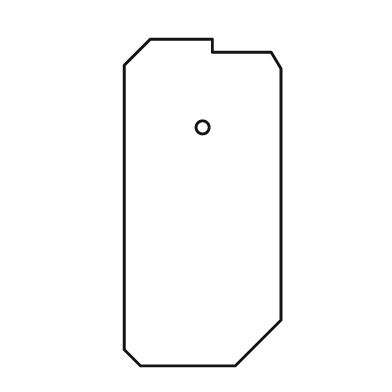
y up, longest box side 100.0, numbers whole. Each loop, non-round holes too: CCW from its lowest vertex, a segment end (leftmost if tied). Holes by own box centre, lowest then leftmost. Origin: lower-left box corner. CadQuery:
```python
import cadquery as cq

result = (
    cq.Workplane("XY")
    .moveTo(5.0, 0.0)
    .lineTo(34.0, 0.0)
    .lineTo(48.0, 14.0)
    .lineTo(48.0, 91.0)
    .lineTo(45.0, 96.0)
    .lineTo(27.0, 96.0)
    .lineTo(27.0, 100.0)
    .lineTo(8.0, 100.0)
    .lineTo(0.0, 92.0)
    .lineTo(0.0, 5.0)
    .close()
    .moveTo(24.0, 73.0)
    .circle(2.0)
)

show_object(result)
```